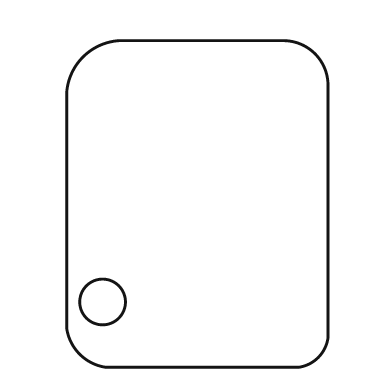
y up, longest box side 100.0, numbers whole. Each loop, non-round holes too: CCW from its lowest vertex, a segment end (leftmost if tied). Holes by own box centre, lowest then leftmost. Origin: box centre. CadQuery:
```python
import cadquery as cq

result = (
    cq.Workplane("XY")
    .moveTo(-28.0, -50.0)
    .lineTo(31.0, -50.0)
    .threePointArc((37.0, -47.0), (40.0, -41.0))
    .lineTo(40.0, 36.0)
    .threePointArc((36.0, 46.0), (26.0, 50.0))
    .lineTo(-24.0, 50.0)
    .threePointArc((-35.0, 45.0), (-40.0, 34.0))
    .lineTo(-40.0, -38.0)
    .threePointArc((-36.0, -46.0), (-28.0, -50.0))
    .close()
    .moveTo(-29.0, -30.0)
    .circle(7.0)
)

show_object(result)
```